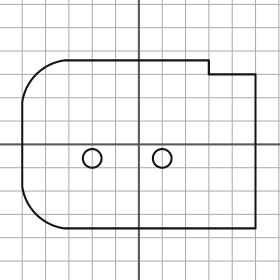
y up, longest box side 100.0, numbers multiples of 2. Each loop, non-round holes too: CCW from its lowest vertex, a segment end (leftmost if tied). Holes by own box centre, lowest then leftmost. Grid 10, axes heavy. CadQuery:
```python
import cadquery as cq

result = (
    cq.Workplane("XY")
    .moveTo(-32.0, -36.0)
    .lineTo(50.0, -36.0)
    .lineTo(50.0, 30.0)
    .lineTo(30.0, 30.0)
    .lineTo(30.0, 36.0)
    .lineTo(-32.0, 36.0)
    .threePointArc((-44.0, 30.0), (-50.0, 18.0))
    .lineTo(-50.0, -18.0)
    .threePointArc((-44.0, -30.0), (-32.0, -36.0))
    .close()
    .moveTo(-20.0, -6.0)
    .circle(4.0)
    .moveTo(10.0, -6.0)
    .circle(4.0)
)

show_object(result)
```